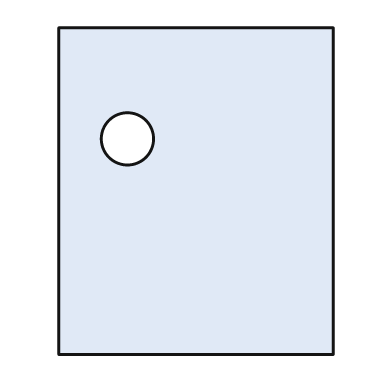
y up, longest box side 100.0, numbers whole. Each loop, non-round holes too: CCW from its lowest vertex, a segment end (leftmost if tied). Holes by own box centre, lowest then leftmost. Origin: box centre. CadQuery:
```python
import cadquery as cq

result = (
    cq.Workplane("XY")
    .moveTo(-42.0, -50.0)
    .lineTo(42.0, -50.0)
    .lineTo(42.0, 50.0)
    .lineTo(-42.0, 50.0)
    .close()
    .moveTo(-21.0, 16.0)
    .circle(8.0)
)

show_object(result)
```